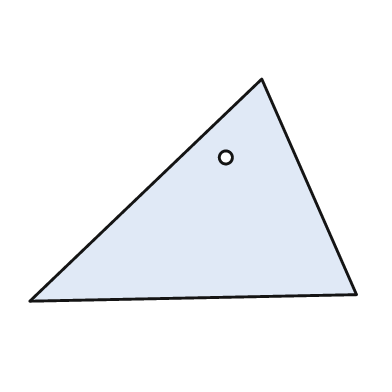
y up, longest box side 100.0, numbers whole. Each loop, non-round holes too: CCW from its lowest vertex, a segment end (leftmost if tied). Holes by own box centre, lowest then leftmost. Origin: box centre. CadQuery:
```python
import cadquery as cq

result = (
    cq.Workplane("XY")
    .moveTo(-50.0, -34.0)
    .lineTo(50.0, -32.0)
    .lineTo(21.0, 34.0)
    .close()
    .moveTo(10.0, 10.0)
    .circle(2.0)
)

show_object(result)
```